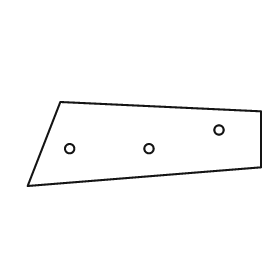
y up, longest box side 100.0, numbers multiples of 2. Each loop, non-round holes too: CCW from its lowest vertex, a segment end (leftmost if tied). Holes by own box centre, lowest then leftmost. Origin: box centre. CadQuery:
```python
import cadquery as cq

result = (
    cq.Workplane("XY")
    .moveTo(-50.0, -18.0)
    .lineTo(50.0, -10.0)
    .lineTo(50.0, 14.0)
    .lineTo(-36.0, 18.0)
    .close()
    .moveTo(-32.0, -2.0)
    .circle(2.0)
    .moveTo(2.0, -2.0)
    .circle(2.0)
    .moveTo(32.0, 6.0)
    .circle(2.0)
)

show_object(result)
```